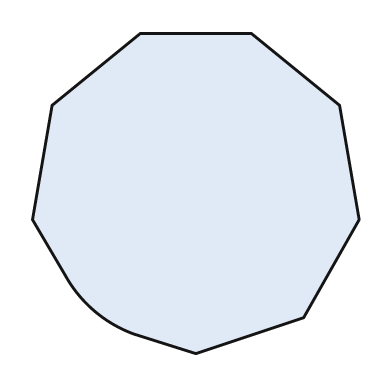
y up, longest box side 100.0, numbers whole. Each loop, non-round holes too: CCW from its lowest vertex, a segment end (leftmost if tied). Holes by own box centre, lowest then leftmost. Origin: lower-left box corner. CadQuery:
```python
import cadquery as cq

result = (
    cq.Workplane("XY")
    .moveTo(50.0, 0.0)
    .lineTo(83.0, 11.0)
    .lineTo(100.0, 41.0)
    .lineTo(94.0, 76.0)
    .lineTo(67.0, 98.0)
    .lineTo(33.0, 98.0)
    .lineTo(6.0, 76.0)
    .lineTo(0.0, 41.0)
    .lineTo(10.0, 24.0)
    .threePointArc((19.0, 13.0), (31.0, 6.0))
    .close()
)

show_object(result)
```